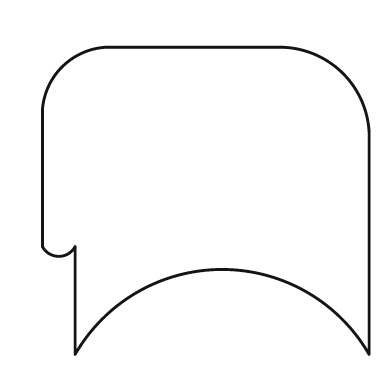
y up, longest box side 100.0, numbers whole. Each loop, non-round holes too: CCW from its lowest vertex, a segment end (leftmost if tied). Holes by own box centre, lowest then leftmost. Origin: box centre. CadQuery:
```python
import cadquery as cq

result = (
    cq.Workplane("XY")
    .moveTo(-40.0, -47.0)
    .threePointArc((5.0, -21.0), (50.0, -47.0))
    .lineTo(50.0, 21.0)
    .threePointArc((42.0, 39.0), (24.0, 47.0))
    .lineTo(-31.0, 47.0)
    .threePointArc((-44.0, 41.0), (-50.0, 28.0))
    .lineTo(-50.0, -14.0)
    .threePointArc((-45.0, -17.0), (-40.0, -14.0))
    .close()
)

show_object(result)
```